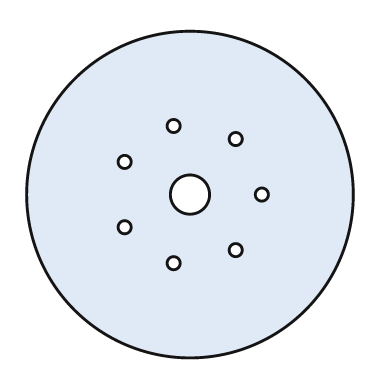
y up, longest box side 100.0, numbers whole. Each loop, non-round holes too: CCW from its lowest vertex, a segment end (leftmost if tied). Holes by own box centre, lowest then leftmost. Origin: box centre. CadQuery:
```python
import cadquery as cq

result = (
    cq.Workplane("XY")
    .moveTo(0.0, 0.0)
    .circle(50.0)
    .moveTo(-5.0, -21.0)
    .circle(2.0)
    .moveTo(14.0, -17.0)
    .circle(2.0)
    .moveTo(-20.0, -10.0)
    .circle(2.0)
    .moveTo(0.0, 0.0)
    .circle(6.0)
    .moveTo(22.0, 0.0)
    .circle(2.0)
    .moveTo(-20.0, 10.0)
    .circle(2.0)
    .moveTo(14.0, 17.0)
    .circle(2.0)
    .moveTo(-5.0, 21.0)
    .circle(2.0)
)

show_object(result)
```